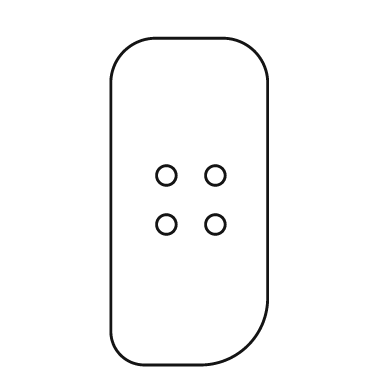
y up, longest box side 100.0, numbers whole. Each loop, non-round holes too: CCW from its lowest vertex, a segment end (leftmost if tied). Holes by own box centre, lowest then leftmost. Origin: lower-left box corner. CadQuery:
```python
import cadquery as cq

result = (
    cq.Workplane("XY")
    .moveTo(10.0, 0.0)
    .lineTo(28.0, 0.0)
    .threePointArc((42.0, 6.0), (48.0, 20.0))
    .lineTo(48.0, 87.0)
    .threePointArc((44.0, 96.0), (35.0, 100.0))
    .lineTo(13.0, 100.0)
    .threePointArc((4.0, 96.0), (0.0, 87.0))
    .lineTo(0.0, 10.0)
    .threePointArc((3.0, 3.0), (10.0, 0.0))
    .close()
    .moveTo(17.0, 43.0)
    .circle(3.0)
    .moveTo(32.0, 43.0)
    .circle(3.0)
    .moveTo(17.0, 58.0)
    .circle(3.0)
    .moveTo(32.0, 58.0)
    .circle(3.0)
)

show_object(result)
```